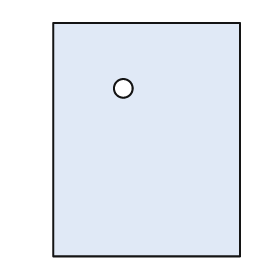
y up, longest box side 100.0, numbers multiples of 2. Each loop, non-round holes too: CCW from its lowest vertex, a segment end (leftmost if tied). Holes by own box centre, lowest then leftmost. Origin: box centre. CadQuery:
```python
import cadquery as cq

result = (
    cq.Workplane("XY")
    .moveTo(-40.0, -50.0)
    .lineTo(40.0, -50.0)
    .lineTo(40.0, 50.0)
    .lineTo(-40.0, 50.0)
    .close()
    .moveTo(-10.0, 22.0)
    .circle(4.0)
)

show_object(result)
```